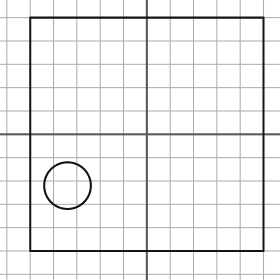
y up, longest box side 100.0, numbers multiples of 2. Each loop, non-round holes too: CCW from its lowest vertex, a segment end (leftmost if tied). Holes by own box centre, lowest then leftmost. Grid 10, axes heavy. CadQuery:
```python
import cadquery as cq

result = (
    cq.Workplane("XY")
    .moveTo(-50.0, -50.0)
    .lineTo(50.0, -50.0)
    .lineTo(50.0, 50.0)
    .lineTo(-50.0, 50.0)
    .close()
    .moveTo(-34.0, -22.0)
    .circle(10.0)
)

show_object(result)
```